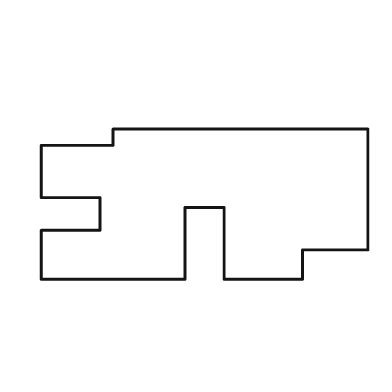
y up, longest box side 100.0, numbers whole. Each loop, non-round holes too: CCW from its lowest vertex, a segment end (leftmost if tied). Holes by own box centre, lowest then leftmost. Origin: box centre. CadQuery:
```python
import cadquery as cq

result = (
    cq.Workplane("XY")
    .moveTo(-50.0, -23.0)
    .lineTo(-6.0, -23.0)
    .lineTo(-6.0, -1.0)
    .lineTo(6.0, -1.0)
    .lineTo(6.0, -23.0)
    .lineTo(30.0, -23.0)
    .lineTo(30.0, -14.0)
    .lineTo(50.0, -14.0)
    .lineTo(50.0, 23.0)
    .lineTo(-28.0, 23.0)
    .lineTo(-28.0, 18.0)
    .lineTo(-50.0, 18.0)
    .lineTo(-50.0, 2.0)
    .lineTo(-32.0, 2.0)
    .lineTo(-32.0, -8.0)
    .lineTo(-50.0, -8.0)
    .close()
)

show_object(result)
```